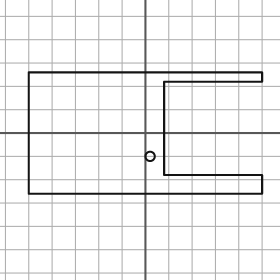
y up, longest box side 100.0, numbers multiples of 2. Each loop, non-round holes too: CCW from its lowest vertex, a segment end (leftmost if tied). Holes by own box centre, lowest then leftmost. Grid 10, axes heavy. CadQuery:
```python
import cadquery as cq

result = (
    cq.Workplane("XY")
    .moveTo(-50.0, -26.0)
    .lineTo(50.0, -26.0)
    .lineTo(50.0, -18.0)
    .lineTo(8.0, -18.0)
    .lineTo(8.0, 22.0)
    .lineTo(50.0, 22.0)
    .lineTo(50.0, 26.0)
    .lineTo(-50.0, 26.0)
    .close()
    .moveTo(2.0, -10.0)
    .circle(2.0)
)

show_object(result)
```